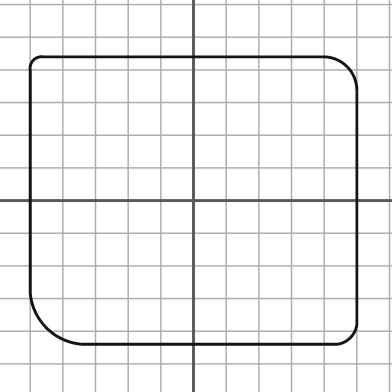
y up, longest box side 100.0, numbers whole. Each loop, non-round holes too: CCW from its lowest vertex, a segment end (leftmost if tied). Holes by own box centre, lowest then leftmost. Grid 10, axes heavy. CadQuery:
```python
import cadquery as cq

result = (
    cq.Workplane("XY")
    .moveTo(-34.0, -44.0)
    .lineTo(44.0, -44.0)
    .threePointArc((48.0, -42.0), (50.0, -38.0))
    .lineTo(50.0, 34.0)
    .threePointArc((47.0, 41.0), (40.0, 44.0))
    .lineTo(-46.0, 44.0)
    .threePointArc((-49.0, 43.0), (-50.0, 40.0))
    .lineTo(-50.0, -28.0)
    .threePointArc((-45.0, -39.0), (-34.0, -44.0))
    .close()
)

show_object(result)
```